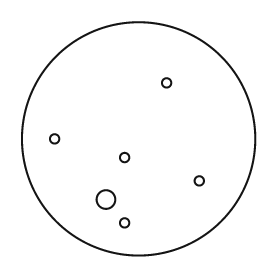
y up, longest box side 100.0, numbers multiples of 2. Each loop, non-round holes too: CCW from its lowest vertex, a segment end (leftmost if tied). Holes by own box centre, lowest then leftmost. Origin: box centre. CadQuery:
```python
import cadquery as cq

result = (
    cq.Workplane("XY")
    .moveTo(0.0, 0.0)
    .circle(50.0)
    .moveTo(-6.0, -36.0)
    .circle(2.0)
    .moveTo(-14.0, -26.0)
    .circle(4.0)
    .moveTo(26.0, -18.0)
    .circle(2.0)
    .moveTo(-6.0, -8.0)
    .circle(2.0)
    .moveTo(-36.0, 0.0)
    .circle(2.0)
    .moveTo(12.0, 24.0)
    .circle(2.0)
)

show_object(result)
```